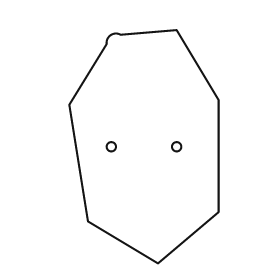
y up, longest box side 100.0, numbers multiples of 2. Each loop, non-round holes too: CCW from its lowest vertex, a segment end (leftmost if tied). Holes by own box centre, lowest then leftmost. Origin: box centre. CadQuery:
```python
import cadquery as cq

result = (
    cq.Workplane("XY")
    .moveTo(6.0, -50.0)
    .lineTo(32.0, -28.0)
    .lineTo(32.0, 20.0)
    .lineTo(14.0, 50.0)
    .lineTo(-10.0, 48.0)
    .threePointArc((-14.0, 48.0), (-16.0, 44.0))
    .lineTo(-32.0, 18.0)
    .lineTo(-24.0, -32.0)
    .close()
    .moveTo(-14.0, 0.0)
    .circle(2.0)
    .moveTo(14.0, 0.0)
    .circle(2.0)
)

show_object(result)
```